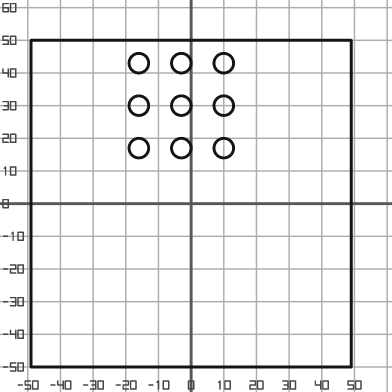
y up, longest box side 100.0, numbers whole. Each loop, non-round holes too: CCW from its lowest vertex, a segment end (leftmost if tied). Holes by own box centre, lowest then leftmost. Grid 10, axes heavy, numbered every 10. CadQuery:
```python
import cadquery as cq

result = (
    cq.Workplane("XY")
    .moveTo(-49.0, -50.0)
    .lineTo(49.0, -50.0)
    .lineTo(49.0, 50.0)
    .lineTo(-49.0, 50.0)
    .close()
    .moveTo(-16.0, 17.0)
    .circle(3.0)
    .moveTo(-3.0, 17.0)
    .circle(3.0)
    .moveTo(10.0, 17.0)
    .circle(3.0)
    .moveTo(-16.0, 30.0)
    .circle(3.0)
    .moveTo(-3.0, 30.0)
    .circle(3.0)
    .moveTo(10.0, 30.0)
    .circle(3.0)
    .moveTo(-16.0, 43.0)
    .circle(3.0)
    .moveTo(-3.0, 43.0)
    .circle(3.0)
    .moveTo(10.0, 43.0)
    .circle(3.0)
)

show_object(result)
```